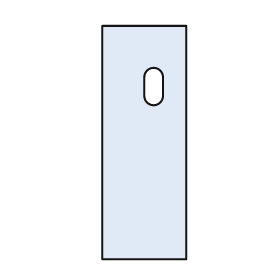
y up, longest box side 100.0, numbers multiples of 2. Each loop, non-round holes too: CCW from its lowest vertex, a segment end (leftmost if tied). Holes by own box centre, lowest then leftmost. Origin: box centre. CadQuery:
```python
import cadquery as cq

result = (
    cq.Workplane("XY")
    .moveTo(-18.0, -50.0)
    .lineTo(18.0, -50.0)
    .lineTo(18.0, 50.0)
    .lineTo(-18.0, 50.0)
    .close()
    .moveTo(0.0, 20.0)
    .threePointArc((4.0, 16.0), (8.0, 20.0))
    .lineTo(8.0, 28.0)
    .threePointArc((4.0, 32.0), (0.0, 28.0))
    .close()
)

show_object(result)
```